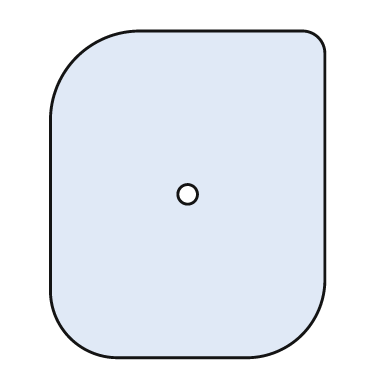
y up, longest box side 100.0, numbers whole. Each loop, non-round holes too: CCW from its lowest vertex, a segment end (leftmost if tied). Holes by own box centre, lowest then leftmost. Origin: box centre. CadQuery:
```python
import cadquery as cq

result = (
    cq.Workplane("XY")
    .moveTo(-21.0, -50.0)
    .lineTo(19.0, -50.0)
    .threePointArc((35.0, -43.0), (42.0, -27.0))
    .lineTo(42.0, 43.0)
    .threePointArc((40.0, 48.0), (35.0, 50.0))
    .lineTo(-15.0, 50.0)
    .threePointArc((-34.0, 42.0), (-42.0, 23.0))
    .lineTo(-42.0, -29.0)
    .threePointArc((-36.0, -44.0), (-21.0, -50.0))
    .close()
    .moveTo(0.0, 0.0)
    .circle(3.0)
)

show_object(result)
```